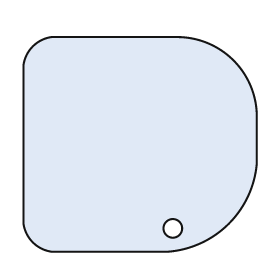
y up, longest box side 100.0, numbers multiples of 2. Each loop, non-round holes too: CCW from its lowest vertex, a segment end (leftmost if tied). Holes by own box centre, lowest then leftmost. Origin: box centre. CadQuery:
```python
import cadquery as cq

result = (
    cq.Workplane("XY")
    .moveTo(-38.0, -46.0)
    .lineTo(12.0, -46.0)
    .threePointArc((38.0, -34.0), (50.0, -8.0))
    .lineTo(50.0, 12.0)
    .threePointArc((40.0, 36.0), (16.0, 46.0))
    .lineTo(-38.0, 46.0)
    .threePointArc((-46.0, 42.0), (-50.0, 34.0))
    .lineTo(-50.0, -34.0)
    .threePointArc((-46.0, -42.0), (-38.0, -46.0))
    .close()
    .moveTo(14.0, -36.0)
    .circle(4.0)
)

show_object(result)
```